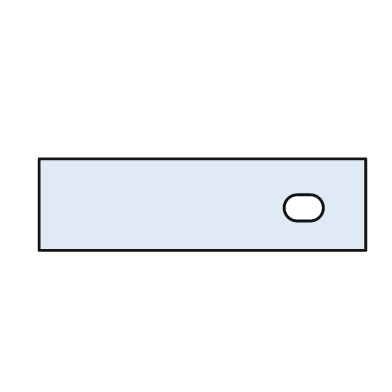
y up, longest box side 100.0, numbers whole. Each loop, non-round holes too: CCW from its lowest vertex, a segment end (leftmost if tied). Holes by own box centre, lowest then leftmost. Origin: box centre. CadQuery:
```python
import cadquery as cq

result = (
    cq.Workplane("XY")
    .moveTo(-50.0, -14.0)
    .lineTo(50.0, -14.0)
    .lineTo(50.0, 14.0)
    .lineTo(-50.0, 14.0)
    .close()
    .moveTo(29.0, -5.0)
    .lineTo(33.0, -5.0)
    .threePointArc((37.0, -1.0), (33.0, 3.0))
    .lineTo(29.0, 3.0)
    .threePointArc((25.0, -1.0), (29.0, -5.0))
    .close()
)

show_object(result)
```